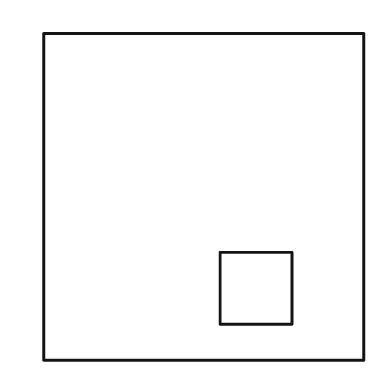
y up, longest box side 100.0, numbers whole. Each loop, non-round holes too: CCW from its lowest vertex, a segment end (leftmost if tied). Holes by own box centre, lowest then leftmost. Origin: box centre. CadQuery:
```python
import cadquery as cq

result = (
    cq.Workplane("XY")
    .moveTo(-49.0, -50.0)
    .lineTo(49.0, -50.0)
    .lineTo(49.0, 50.0)
    .lineTo(-49.0, 50.0)
    .close()
    .moveTo(5.0, -39.0)
    .lineTo(27.0, -39.0)
    .lineTo(27.0, -17.0)
    .lineTo(5.0, -17.0)
    .close()
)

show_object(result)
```